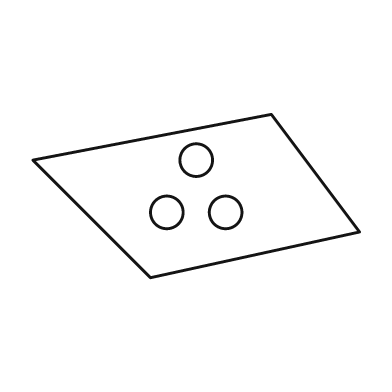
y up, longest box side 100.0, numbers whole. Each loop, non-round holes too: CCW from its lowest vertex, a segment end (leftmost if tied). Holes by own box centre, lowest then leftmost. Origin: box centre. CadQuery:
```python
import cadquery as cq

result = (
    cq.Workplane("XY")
    .moveTo(-14.0, -25.0)
    .lineTo(50.0, -11.0)
    .lineTo(23.0, 25.0)
    .lineTo(-50.0, 11.0)
    .close()
    .moveTo(-9.0, -5.0)
    .circle(5.0)
    .moveTo(9.0, -5.0)
    .circle(5.0)
    .moveTo(0.0, 11.0)
    .circle(5.0)
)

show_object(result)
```